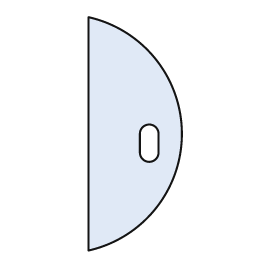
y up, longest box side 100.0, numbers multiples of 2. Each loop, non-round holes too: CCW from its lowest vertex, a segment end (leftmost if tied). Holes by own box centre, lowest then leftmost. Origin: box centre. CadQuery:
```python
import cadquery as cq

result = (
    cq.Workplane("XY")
    .moveTo(-20.0, -50.0)
    .threePointArc((20.0, 0.0), (-20.0, 50.0))
    .close()
    .moveTo(2.0, -8.0)
    .threePointArc((6.0, -12.0), (10.0, -8.0))
    .lineTo(10.0, 0.0)
    .threePointArc((6.0, 4.0), (2.0, 0.0))
    .close()
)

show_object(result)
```